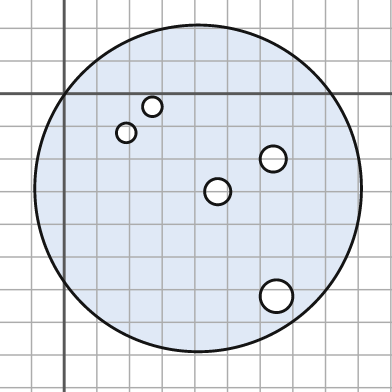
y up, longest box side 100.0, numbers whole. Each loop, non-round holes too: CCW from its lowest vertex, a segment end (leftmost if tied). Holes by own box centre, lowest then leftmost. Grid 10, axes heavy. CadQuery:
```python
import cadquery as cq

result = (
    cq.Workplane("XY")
    .moveTo(41.0, -29.0)
    .circle(50.0)
    .moveTo(65.0, -62.0)
    .circle(5.0)
    .moveTo(47.0, -30.0)
    .circle(4.0)
    .moveTo(64.0, -20.0)
    .circle(4.0)
    .moveTo(19.0, -12.0)
    .circle(3.0)
    .moveTo(27.0, -4.0)
    .circle(3.0)
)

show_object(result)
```